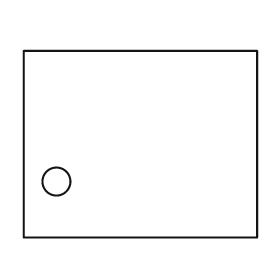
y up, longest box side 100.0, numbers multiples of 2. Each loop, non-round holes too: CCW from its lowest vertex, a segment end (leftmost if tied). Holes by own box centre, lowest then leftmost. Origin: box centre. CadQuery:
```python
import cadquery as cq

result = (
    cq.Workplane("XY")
    .moveTo(-50.0, -40.0)
    .lineTo(50.0, -40.0)
    .lineTo(50.0, 40.0)
    .lineTo(-50.0, 40.0)
    .close()
    .moveTo(-36.0, -16.0)
    .circle(6.0)
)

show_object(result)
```